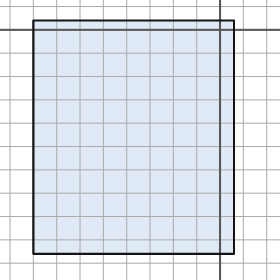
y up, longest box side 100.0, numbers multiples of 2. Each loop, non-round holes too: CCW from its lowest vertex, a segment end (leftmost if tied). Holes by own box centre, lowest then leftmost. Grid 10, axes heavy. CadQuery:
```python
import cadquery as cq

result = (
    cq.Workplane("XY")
    .moveTo(-80.0, -96.0)
    .lineTo(6.0, -96.0)
    .lineTo(6.0, 4.0)
    .lineTo(-80.0, 4.0)
    .close()
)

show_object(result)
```